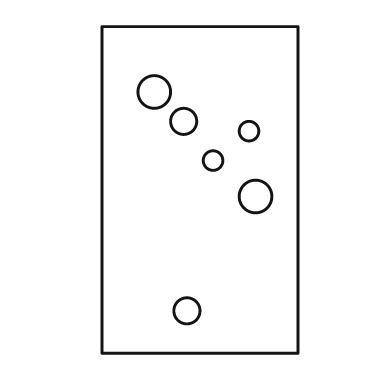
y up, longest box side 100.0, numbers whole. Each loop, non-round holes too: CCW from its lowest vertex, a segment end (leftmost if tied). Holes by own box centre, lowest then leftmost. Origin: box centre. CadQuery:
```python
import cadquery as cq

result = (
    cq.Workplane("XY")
    .moveTo(-30.0, -50.0)
    .lineTo(30.0, -50.0)
    .lineTo(30.0, 50.0)
    .lineTo(-30.0, 50.0)
    .close()
    .moveTo(-4.0, -37.0)
    .circle(4.0)
    .moveTo(17.0, -2.0)
    .circle(5.0)
    .moveTo(4.0, 9.0)
    .circle(3.0)
    .moveTo(15.0, 18.0)
    .circle(3.0)
    .moveTo(-5.0, 21.0)
    .circle(4.0)
    .moveTo(-14.0, 30.0)
    .circle(5.0)
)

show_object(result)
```